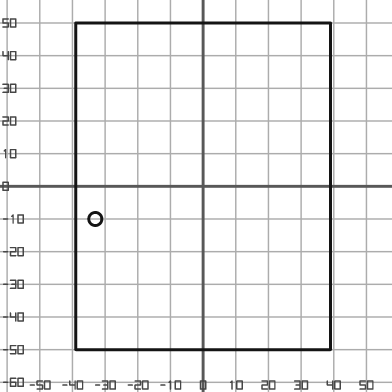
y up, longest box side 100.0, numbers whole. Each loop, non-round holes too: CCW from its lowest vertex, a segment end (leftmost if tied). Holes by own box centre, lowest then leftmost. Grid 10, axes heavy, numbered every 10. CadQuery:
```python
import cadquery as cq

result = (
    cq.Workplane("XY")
    .moveTo(-39.0, -50.0)
    .lineTo(39.0, -50.0)
    .lineTo(39.0, 50.0)
    .lineTo(-39.0, 50.0)
    .close()
    .moveTo(-33.0, -10.0)
    .circle(2.0)
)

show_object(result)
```